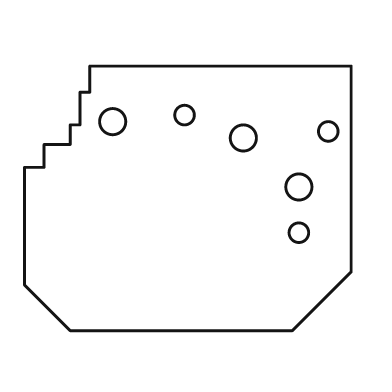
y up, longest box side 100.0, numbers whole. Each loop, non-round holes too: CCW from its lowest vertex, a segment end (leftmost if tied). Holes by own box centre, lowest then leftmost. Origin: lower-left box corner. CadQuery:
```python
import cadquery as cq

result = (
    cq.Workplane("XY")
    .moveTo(14.0, 0.0)
    .lineTo(82.0, 0.0)
    .lineTo(100.0, 18.0)
    .lineTo(100.0, 81.0)
    .lineTo(20.0, 81.0)
    .lineTo(20.0, 73.0)
    .lineTo(17.0, 73.0)
    .lineTo(17.0, 63.0)
    .lineTo(14.0, 63.0)
    .lineTo(14.0, 57.0)
    .lineTo(6.0, 57.0)
    .lineTo(6.0, 50.0)
    .lineTo(0.0, 50.0)
    .lineTo(0.0, 14.0)
    .close()
    .moveTo(84.0, 30.0)
    .circle(3.0)
    .moveTo(84.0, 44.0)
    .circle(4.0)
    .moveTo(67.0, 59.0)
    .circle(4.0)
    .moveTo(93.0, 61.0)
    .circle(3.0)
    .moveTo(27.0, 64.0)
    .circle(4.0)
    .moveTo(49.0, 66.0)
    .circle(3.0)
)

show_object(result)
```